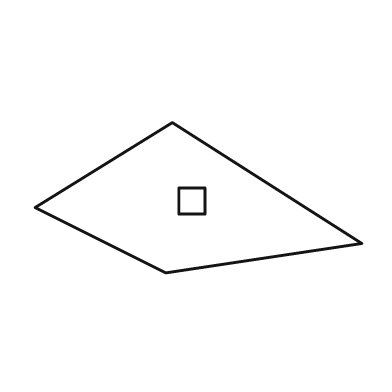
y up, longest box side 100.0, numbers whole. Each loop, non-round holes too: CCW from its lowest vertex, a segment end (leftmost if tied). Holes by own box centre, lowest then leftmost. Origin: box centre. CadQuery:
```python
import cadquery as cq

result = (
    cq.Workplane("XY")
    .moveTo(-10.0, -23.0)
    .lineTo(50.0, -14.0)
    .lineTo(-8.0, 23.0)
    .lineTo(-50.0, -3.0)
    .close()
    .moveTo(-6.0, -5.0)
    .lineTo(2.0, -5.0)
    .lineTo(2.0, 3.0)
    .lineTo(-6.0, 3.0)
    .close()
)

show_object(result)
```